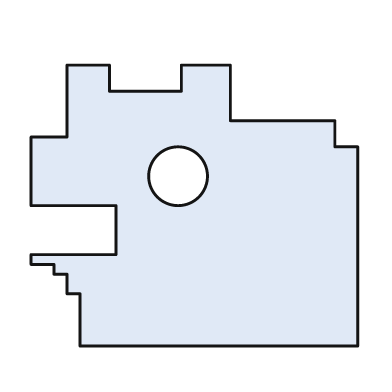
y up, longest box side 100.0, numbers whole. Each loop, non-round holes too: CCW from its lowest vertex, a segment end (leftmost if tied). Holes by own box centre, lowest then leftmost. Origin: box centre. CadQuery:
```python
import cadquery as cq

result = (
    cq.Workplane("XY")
    .moveTo(-35.0, -43.0)
    .lineTo(50.0, -43.0)
    .lineTo(50.0, 18.0)
    .lineTo(43.0, 18.0)
    .lineTo(43.0, 26.0)
    .lineTo(11.0, 26.0)
    .lineTo(11.0, 43.0)
    .lineTo(-4.0, 43.0)
    .lineTo(-4.0, 35.0)
    .lineTo(-26.0, 35.0)
    .lineTo(-26.0, 43.0)
    .lineTo(-39.0, 43.0)
    .lineTo(-39.0, 21.0)
    .lineTo(-50.0, 21.0)
    .lineTo(-50.0, 0.0)
    .lineTo(-24.0, 0.0)
    .lineTo(-24.0, -15.0)
    .lineTo(-50.0, -15.0)
    .lineTo(-50.0, -18.0)
    .lineTo(-43.0, -18.0)
    .lineTo(-43.0, -21.0)
    .lineTo(-39.0, -21.0)
    .lineTo(-39.0, -27.0)
    .lineTo(-35.0, -27.0)
    .close()
    .moveTo(-5.0, 9.0)
    .circle(9.0)
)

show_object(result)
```